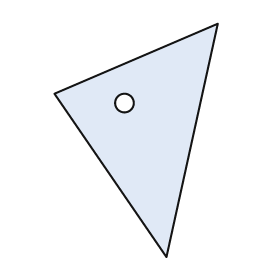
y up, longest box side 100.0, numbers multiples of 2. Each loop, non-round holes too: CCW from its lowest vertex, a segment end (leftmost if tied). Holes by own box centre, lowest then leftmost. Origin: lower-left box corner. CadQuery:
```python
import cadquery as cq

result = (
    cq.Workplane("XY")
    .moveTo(48.0, 0.0)
    .lineTo(70.0, 100.0)
    .lineTo(0.0, 70.0)
    .close()
    .moveTo(30.0, 66.0)
    .circle(4.0)
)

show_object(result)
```